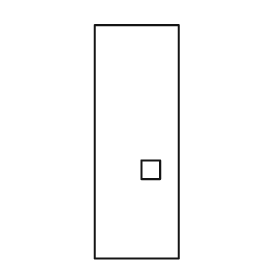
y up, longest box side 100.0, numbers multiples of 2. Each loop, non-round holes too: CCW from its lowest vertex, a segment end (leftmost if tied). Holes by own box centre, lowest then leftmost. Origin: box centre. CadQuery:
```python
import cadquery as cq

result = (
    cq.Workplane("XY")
    .moveTo(-18.0, -50.0)
    .lineTo(18.0, -50.0)
    .lineTo(18.0, 50.0)
    .lineTo(-18.0, 50.0)
    .close()
    .moveTo(2.0, -16.0)
    .lineTo(10.0, -16.0)
    .lineTo(10.0, -8.0)
    .lineTo(2.0, -8.0)
    .close()
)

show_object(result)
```